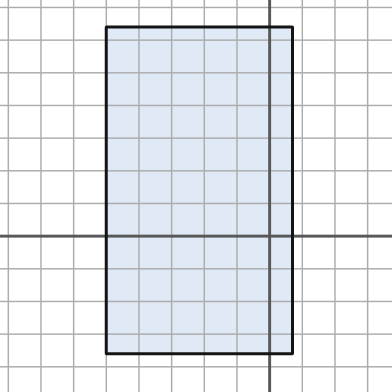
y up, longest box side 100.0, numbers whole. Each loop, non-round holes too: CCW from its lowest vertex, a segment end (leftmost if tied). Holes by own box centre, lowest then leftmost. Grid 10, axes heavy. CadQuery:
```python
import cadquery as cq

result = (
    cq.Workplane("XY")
    .moveTo(-50.0, -36.0)
    .lineTo(7.0, -36.0)
    .lineTo(7.0, 64.0)
    .lineTo(-50.0, 64.0)
    .close()
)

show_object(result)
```